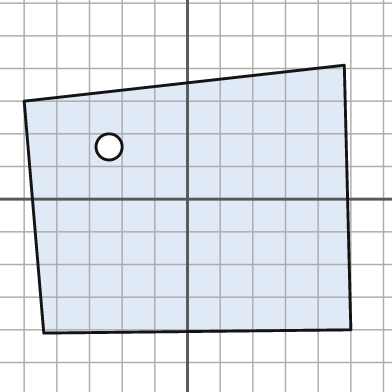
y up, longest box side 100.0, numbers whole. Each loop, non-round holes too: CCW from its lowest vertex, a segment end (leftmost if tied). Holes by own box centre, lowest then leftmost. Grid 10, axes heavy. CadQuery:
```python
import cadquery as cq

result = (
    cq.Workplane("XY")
    .moveTo(-44.0, -41.0)
    .lineTo(50.0, -40.0)
    .lineTo(48.0, 41.0)
    .lineTo(-50.0, 30.0)
    .close()
    .moveTo(-24.0, 16.0)
    .circle(4.0)
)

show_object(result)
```